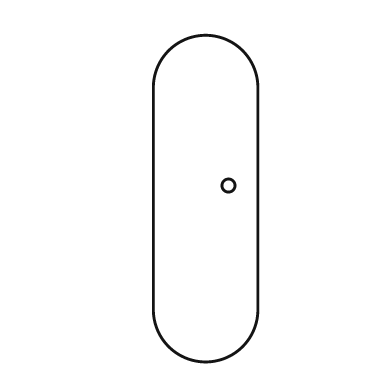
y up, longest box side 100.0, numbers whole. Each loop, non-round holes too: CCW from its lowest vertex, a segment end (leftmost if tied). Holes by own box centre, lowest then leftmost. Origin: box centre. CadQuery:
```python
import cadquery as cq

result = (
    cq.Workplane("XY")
    .moveTo(-16.0, -34.0)
    .threePointArc((0.0, -50.0), (16.0, -34.0))
    .lineTo(16.0, 34.0)
    .threePointArc((0.0, 50.0), (-16.0, 34.0))
    .close()
    .moveTo(7.0, 4.0)
    .circle(2.0)
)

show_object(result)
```